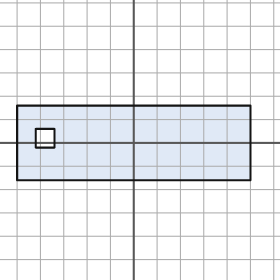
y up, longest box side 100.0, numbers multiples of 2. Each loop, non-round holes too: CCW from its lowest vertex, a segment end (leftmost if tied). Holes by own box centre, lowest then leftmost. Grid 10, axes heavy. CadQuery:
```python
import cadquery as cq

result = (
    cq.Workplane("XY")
    .moveTo(-50.0, -16.0)
    .lineTo(50.0, -16.0)
    .lineTo(50.0, 16.0)
    .lineTo(-50.0, 16.0)
    .close()
    .moveTo(-42.0, -2.0)
    .lineTo(-34.0, -2.0)
    .lineTo(-34.0, 6.0)
    .lineTo(-42.0, 6.0)
    .close()
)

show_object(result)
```